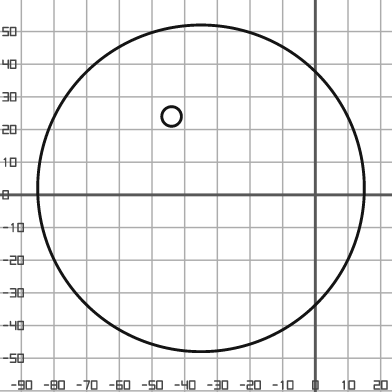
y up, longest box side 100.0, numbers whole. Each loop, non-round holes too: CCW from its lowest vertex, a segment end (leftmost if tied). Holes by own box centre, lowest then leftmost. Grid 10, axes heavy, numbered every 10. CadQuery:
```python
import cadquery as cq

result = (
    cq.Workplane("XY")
    .moveTo(-35.0, 2.0)
    .circle(50.0)
    .moveTo(-44.0, 24.0)
    .circle(3.0)
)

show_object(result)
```